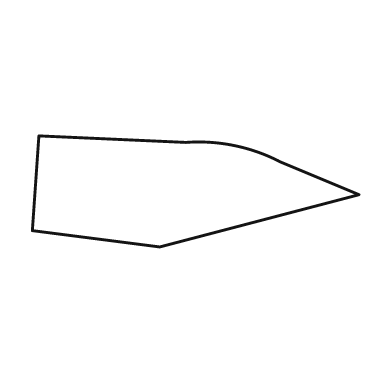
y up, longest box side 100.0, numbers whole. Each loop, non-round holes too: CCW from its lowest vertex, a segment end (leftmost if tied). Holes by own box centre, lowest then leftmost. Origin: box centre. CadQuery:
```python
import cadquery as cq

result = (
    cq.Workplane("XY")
    .moveTo(-11.0, -17.0)
    .lineTo(50.0, -1.0)
    .lineTo(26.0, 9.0)
    .threePointArc((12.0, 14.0), (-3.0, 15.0))
    .lineTo(-48.0, 17.0)
    .lineTo(-50.0, -12.0)
    .close()
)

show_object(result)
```